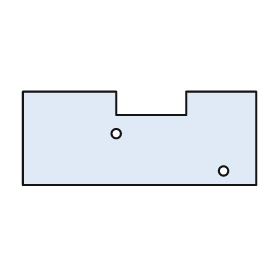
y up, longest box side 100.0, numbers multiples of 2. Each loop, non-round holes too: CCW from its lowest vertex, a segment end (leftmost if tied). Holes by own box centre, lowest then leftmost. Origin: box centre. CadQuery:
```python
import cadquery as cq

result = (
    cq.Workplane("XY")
    .moveTo(-50.0, -20.0)
    .lineTo(50.0, -20.0)
    .lineTo(50.0, 20.0)
    .lineTo(20.0, 20.0)
    .lineTo(20.0, 10.0)
    .lineTo(-10.0, 10.0)
    .lineTo(-10.0, 20.0)
    .lineTo(-50.0, 20.0)
    .close()
    .moveTo(36.0, -14.0)
    .circle(2.0)
    .moveTo(-10.0, 2.0)
    .circle(2.0)
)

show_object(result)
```